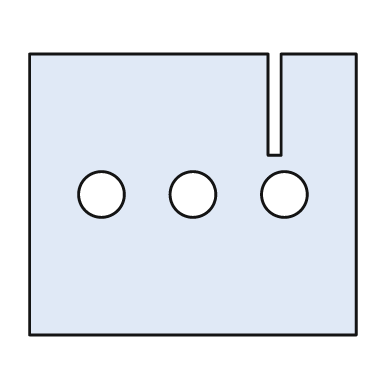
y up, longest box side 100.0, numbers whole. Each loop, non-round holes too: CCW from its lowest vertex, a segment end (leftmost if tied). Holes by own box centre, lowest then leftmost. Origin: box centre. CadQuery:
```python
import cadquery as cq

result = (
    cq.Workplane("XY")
    .moveTo(-50.0, -43.0)
    .lineTo(50.0, -43.0)
    .lineTo(50.0, 43.0)
    .lineTo(27.0, 43.0)
    .lineTo(27.0, 12.0)
    .lineTo(23.0, 12.0)
    .lineTo(23.0, 43.0)
    .lineTo(-50.0, 43.0)
    .close()
    .moveTo(-28.0, 0.0)
    .circle(7.0)
    .moveTo(0.0, 0.0)
    .circle(7.0)
    .moveTo(28.0, 0.0)
    .circle(7.0)
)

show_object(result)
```